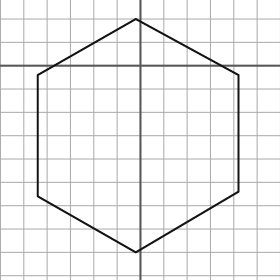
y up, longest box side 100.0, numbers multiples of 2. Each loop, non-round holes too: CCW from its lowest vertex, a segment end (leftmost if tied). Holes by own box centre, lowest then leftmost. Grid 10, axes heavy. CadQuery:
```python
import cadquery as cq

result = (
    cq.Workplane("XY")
    .moveTo(-2.0, -80.0)
    .lineTo(42.0, -54.0)
    .lineTo(42.0, -4.0)
    .lineTo(-2.0, 20.0)
    .lineTo(-44.0, -4.0)
    .lineTo(-44.0, -56.0)
    .close()
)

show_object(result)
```